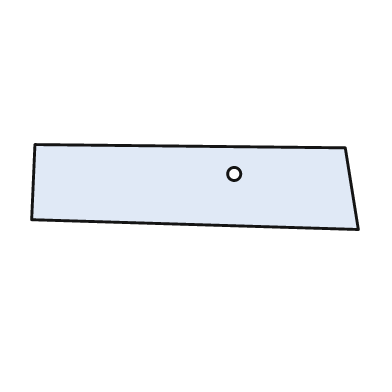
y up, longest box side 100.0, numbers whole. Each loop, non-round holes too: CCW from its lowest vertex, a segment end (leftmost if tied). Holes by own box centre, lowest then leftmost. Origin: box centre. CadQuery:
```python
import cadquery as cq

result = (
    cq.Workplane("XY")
    .moveTo(50.0, -13.0)
    .lineTo(46.0, 12.0)
    .lineTo(-49.0, 13.0)
    .lineTo(-50.0, -10.0)
    .close()
    .moveTo(12.0, 4.0)
    .circle(2.0)
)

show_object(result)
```